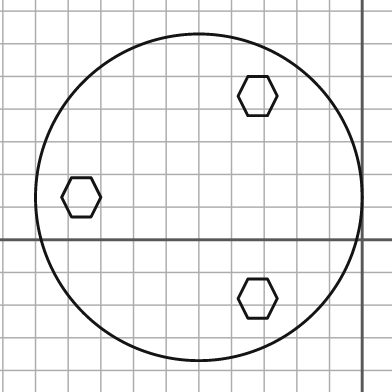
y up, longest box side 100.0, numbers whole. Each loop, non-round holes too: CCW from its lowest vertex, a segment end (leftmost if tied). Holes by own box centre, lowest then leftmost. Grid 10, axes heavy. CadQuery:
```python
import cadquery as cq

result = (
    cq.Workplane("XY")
    .moveTo(-50.0, 13.0)
    .circle(50.0)
    .moveTo(-35.0, -24.0)
    .lineTo(-29.0, -24.0)
    .lineTo(-26.0, -18.0)
    .lineTo(-29.0, -12.0)
    .lineTo(-35.0, -12.0)
    .lineTo(-38.0, -18.0)
    .close()
    .moveTo(-89.0, 7.0)
    .lineTo(-83.0, 7.0)
    .lineTo(-80.0, 13.0)
    .lineTo(-83.0, 19.0)
    .lineTo(-89.0, 19.0)
    .lineTo(-92.0, 13.0)
    .close()
    .moveTo(-35.0, 38.0)
    .lineTo(-29.0, 38.0)
    .lineTo(-26.0, 44.0)
    .lineTo(-29.0, 50.0)
    .lineTo(-35.0, 50.0)
    .lineTo(-38.0, 44.0)
    .close()
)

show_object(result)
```